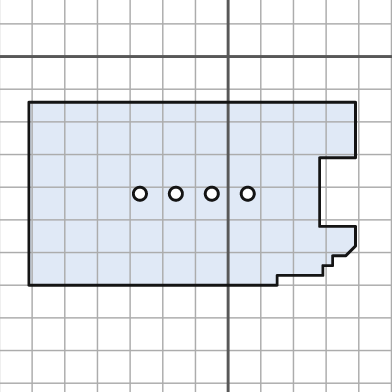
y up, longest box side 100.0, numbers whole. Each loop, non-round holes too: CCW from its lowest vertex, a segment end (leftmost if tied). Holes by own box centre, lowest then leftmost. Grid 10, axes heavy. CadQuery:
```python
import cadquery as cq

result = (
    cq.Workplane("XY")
    .moveTo(-61.0, -70.0)
    .lineTo(15.0, -70.0)
    .lineTo(15.0, -67.0)
    .lineTo(29.0, -67.0)
    .lineTo(29.0, -64.0)
    .lineTo(32.0, -64.0)
    .lineTo(32.0, -61.0)
    .lineTo(36.0, -61.0)
    .lineTo(39.0, -58.0)
    .lineTo(39.0, -52.0)
    .lineTo(28.0, -52.0)
    .lineTo(28.0, -31.0)
    .lineTo(39.0, -31.0)
    .lineTo(39.0, -14.0)
    .lineTo(-61.0, -14.0)
    .close()
    .moveTo(-27.0, -42.0)
    .circle(2.0)
    .moveTo(-16.0, -42.0)
    .circle(2.0)
    .moveTo(-5.0, -42.0)
    .circle(2.0)
    .moveTo(6.0, -42.0)
    .circle(2.0)
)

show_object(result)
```